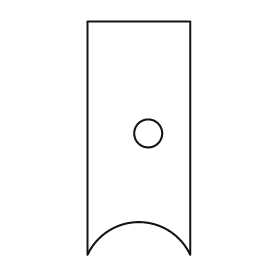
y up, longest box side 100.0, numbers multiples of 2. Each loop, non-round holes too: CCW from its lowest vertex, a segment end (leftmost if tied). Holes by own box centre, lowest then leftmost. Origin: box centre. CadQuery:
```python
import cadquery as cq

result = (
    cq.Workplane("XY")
    .moveTo(-22.0, -50.0)
    .threePointArc((0.0, -36.0), (22.0, -50.0))
    .lineTo(22.0, 50.0)
    .lineTo(-22.0, 50.0)
    .close()
    .moveTo(4.0, 2.0)
    .circle(6.0)
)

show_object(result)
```